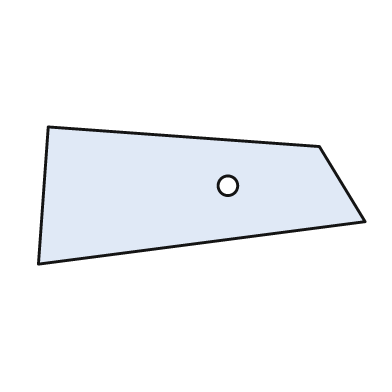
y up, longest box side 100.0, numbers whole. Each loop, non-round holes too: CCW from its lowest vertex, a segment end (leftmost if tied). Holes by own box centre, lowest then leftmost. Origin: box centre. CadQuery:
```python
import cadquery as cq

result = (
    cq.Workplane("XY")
    .moveTo(-50.0, -21.0)
    .lineTo(50.0, -8.0)
    .lineTo(36.0, 15.0)
    .lineTo(-47.0, 21.0)
    .close()
    .moveTo(8.0, 3.0)
    .circle(3.0)
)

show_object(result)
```